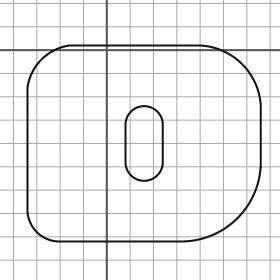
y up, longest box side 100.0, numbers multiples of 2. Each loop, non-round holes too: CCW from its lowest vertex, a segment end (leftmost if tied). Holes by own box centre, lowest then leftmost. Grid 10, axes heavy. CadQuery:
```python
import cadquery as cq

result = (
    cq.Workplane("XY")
    .moveTo(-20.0, -82.0)
    .lineTo(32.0, -82.0)
    .threePointArc((56.0, -72.0), (66.0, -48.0))
    .lineTo(66.0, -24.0)
    .threePointArc((58.0, -6.0), (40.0, 2.0))
    .lineTo(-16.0, 2.0)
    .threePointArc((-28.0, -4.0), (-34.0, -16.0))
    .lineTo(-34.0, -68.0)
    .threePointArc((-30.0, -78.0), (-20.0, -82.0))
    .close()
    .moveTo(8.0, -48.0)
    .threePointArc((16.0, -56.0), (24.0, -48.0))
    .lineTo(24.0, -32.0)
    .threePointArc((16.0, -24.0), (8.0, -32.0))
    .close()
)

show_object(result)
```